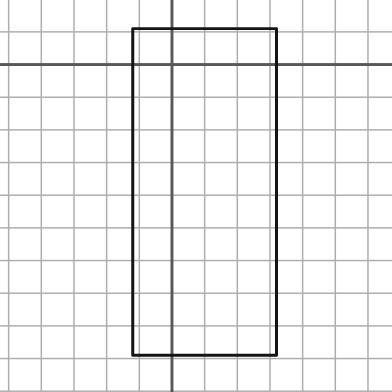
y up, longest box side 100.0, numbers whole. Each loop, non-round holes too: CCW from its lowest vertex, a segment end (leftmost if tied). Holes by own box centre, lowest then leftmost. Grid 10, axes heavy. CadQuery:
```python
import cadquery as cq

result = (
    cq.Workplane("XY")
    .moveTo(-12.0, -89.0)
    .lineTo(32.0, -89.0)
    .lineTo(32.0, 11.0)
    .lineTo(-12.0, 11.0)
    .close()
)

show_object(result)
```